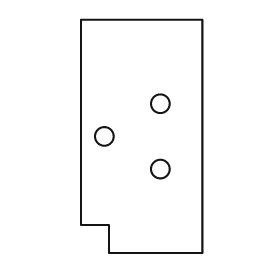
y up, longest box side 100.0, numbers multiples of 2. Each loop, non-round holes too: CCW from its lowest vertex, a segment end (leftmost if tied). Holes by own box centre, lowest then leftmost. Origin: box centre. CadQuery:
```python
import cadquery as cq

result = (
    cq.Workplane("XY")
    .moveTo(-14.0, -50.0)
    .lineTo(26.0, -50.0)
    .lineTo(26.0, 50.0)
    .lineTo(-26.0, 50.0)
    .lineTo(-26.0, -38.0)
    .lineTo(-14.0, -38.0)
    .close()
    .moveTo(8.0, -14.0)
    .circle(4.0)
    .moveTo(-16.0, 0.0)
    .circle(4.0)
    .moveTo(8.0, 14.0)
    .circle(4.0)
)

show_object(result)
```